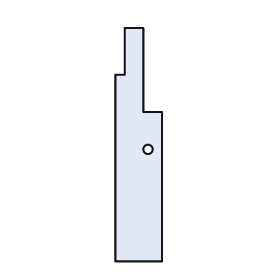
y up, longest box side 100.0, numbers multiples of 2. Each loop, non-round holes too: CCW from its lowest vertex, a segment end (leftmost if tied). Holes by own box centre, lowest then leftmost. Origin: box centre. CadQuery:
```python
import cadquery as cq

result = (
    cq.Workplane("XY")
    .moveTo(-10.0, -50.0)
    .lineTo(10.0, -50.0)
    .lineTo(10.0, 14.0)
    .lineTo(2.0, 14.0)
    .lineTo(2.0, 50.0)
    .lineTo(-6.0, 50.0)
    .lineTo(-6.0, 30.0)
    .lineTo(-10.0, 30.0)
    .close()
    .moveTo(4.0, -2.0)
    .circle(2.0)
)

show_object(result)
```